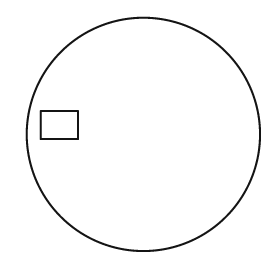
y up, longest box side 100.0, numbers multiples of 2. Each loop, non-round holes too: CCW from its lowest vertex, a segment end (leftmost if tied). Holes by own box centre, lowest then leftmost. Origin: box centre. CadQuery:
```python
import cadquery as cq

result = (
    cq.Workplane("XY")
    .moveTo(0.0, 0.0)
    .circle(50.0)
    .moveTo(-44.0, -2.0)
    .lineTo(-28.0, -2.0)
    .lineTo(-28.0, 10.0)
    .lineTo(-44.0, 10.0)
    .close()
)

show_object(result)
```